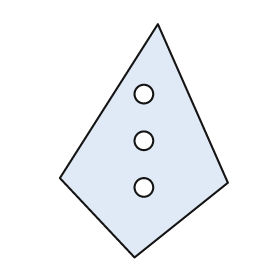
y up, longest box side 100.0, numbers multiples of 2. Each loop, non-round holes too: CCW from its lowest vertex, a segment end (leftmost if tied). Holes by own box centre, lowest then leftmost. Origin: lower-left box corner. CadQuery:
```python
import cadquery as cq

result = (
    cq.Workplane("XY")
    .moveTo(32.0, 0.0)
    .lineTo(72.0, 32.0)
    .lineTo(42.0, 100.0)
    .lineTo(0.0, 34.0)
    .close()
    .moveTo(36.0, 30.0)
    .circle(4.0)
    .moveTo(36.0, 50.0)
    .circle(4.0)
    .moveTo(36.0, 70.0)
    .circle(4.0)
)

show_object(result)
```